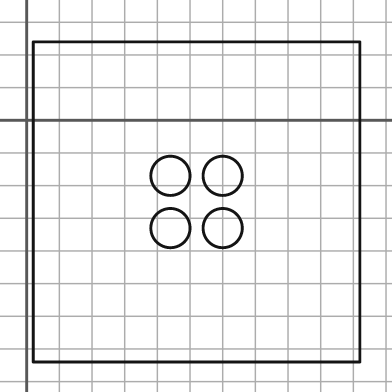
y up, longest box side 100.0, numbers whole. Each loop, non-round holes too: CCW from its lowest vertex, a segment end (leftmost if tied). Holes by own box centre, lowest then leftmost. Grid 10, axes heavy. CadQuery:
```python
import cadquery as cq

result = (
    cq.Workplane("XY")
    .moveTo(2.0, -74.0)
    .lineTo(102.0, -74.0)
    .lineTo(102.0, 24.0)
    .lineTo(2.0, 24.0)
    .close()
    .moveTo(44.0, -33.0)
    .circle(6.0)
    .moveTo(60.0, -33.0)
    .circle(6.0)
    .moveTo(44.0, -17.0)
    .circle(6.0)
    .moveTo(60.0, -17.0)
    .circle(6.0)
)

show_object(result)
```